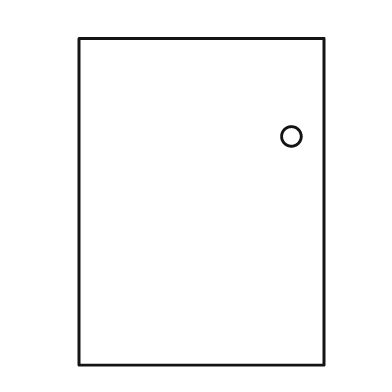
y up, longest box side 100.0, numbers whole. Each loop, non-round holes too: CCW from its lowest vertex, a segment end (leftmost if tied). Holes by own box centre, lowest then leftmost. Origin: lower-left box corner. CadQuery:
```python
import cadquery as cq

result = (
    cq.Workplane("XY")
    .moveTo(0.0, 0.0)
    .lineTo(75.0, 0.0)
    .lineTo(75.0, 100.0)
    .lineTo(0.0, 100.0)
    .close()
    .moveTo(65.0, 70.0)
    .circle(3.0)
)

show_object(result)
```